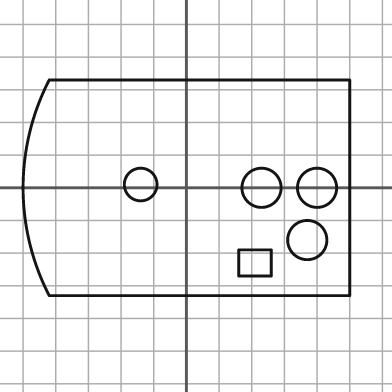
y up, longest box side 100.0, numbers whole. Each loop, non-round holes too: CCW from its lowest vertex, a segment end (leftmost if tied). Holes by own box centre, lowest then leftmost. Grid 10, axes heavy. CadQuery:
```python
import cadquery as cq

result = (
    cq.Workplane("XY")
    .moveTo(-42.0, -33.0)
    .lineTo(50.0, -33.0)
    .lineTo(50.0, 33.0)
    .lineTo(-42.0, 33.0)
    .threePointArc((-50.0, 0.0), (-42.0, -33.0))
    .close()
    .moveTo(16.0, -27.0)
    .lineTo(26.0, -27.0)
    .lineTo(26.0, -19.0)
    .lineTo(16.0, -19.0)
    .close()
    .moveTo(37.0, -16.0)
    .circle(6.0)
    .moveTo(23.0, 0.0)
    .circle(6.0)
    .moveTo(40.0, 0.0)
    .circle(6.0)
    .moveTo(-14.0, 1.0)
    .circle(5.0)
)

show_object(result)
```